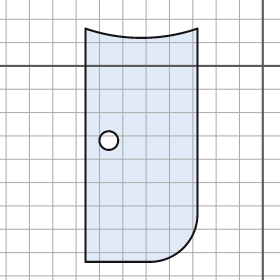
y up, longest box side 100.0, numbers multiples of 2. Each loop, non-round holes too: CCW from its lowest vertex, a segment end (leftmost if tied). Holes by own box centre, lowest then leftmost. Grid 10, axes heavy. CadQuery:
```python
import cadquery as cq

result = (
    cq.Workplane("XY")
    .moveTo(-76.0, -84.0)
    .lineTo(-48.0, -84.0)
    .threePointArc((-34.0, -78.0), (-28.0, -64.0))
    .lineTo(-28.0, 16.0)
    .threePointArc((-52.0, 12.0), (-76.0, 16.0))
    .close()
    .moveTo(-66.0, -32.0)
    .circle(4.0)
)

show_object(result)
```